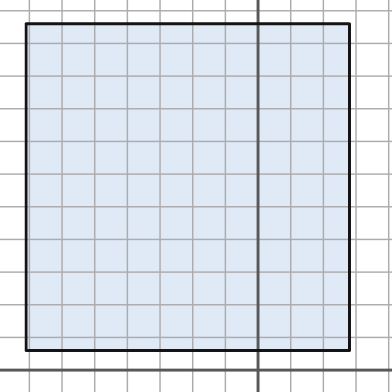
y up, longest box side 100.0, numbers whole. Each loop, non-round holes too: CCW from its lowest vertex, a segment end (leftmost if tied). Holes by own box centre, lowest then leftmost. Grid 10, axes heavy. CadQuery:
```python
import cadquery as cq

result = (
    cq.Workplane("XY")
    .moveTo(-71.0, 6.0)
    .lineTo(28.0, 6.0)
    .lineTo(28.0, 106.0)
    .lineTo(-71.0, 106.0)
    .close()
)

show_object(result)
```